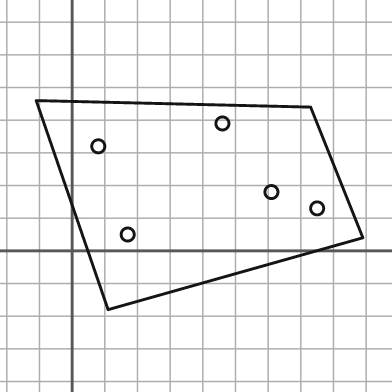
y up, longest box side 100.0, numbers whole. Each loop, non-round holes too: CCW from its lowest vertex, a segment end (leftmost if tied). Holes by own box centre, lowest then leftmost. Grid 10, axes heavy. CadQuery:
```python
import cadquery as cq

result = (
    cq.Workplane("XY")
    .moveTo(11.0, -18.0)
    .lineTo(89.0, 4.0)
    .lineTo(73.0, 44.0)
    .lineTo(-11.0, 46.0)
    .close()
    .moveTo(17.0, 5.0)
    .circle(2.0)
    .moveTo(75.0, 13.0)
    .circle(2.0)
    .moveTo(61.0, 18.0)
    .circle(2.0)
    .moveTo(8.0, 32.0)
    .circle(2.0)
    .moveTo(46.0, 39.0)
    .circle(2.0)
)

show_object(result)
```